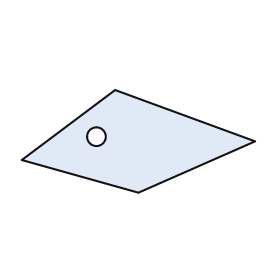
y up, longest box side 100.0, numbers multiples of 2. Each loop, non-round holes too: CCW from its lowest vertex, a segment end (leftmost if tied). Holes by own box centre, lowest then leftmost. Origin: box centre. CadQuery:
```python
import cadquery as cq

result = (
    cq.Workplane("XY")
    .moveTo(0.0, -22.0)
    .lineTo(50.0, 0.0)
    .lineTo(-10.0, 22.0)
    .lineTo(-50.0, -8.0)
    .close()
    .moveTo(-18.0, 2.0)
    .circle(4.0)
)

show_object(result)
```